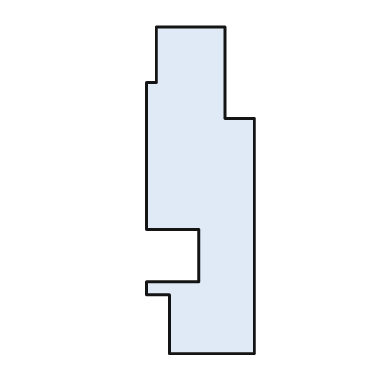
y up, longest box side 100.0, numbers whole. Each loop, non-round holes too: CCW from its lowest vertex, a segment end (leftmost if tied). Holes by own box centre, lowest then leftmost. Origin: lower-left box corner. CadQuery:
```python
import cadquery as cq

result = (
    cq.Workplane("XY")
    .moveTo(7.0, 0.0)
    .lineTo(33.0, 0.0)
    .lineTo(33.0, 72.0)
    .lineTo(24.0, 72.0)
    .lineTo(24.0, 100.0)
    .lineTo(3.0, 100.0)
    .lineTo(3.0, 83.0)
    .lineTo(0.0, 83.0)
    .lineTo(0.0, 38.0)
    .lineTo(16.0, 38.0)
    .lineTo(16.0, 22.0)
    .lineTo(0.0, 22.0)
    .lineTo(0.0, 18.0)
    .lineTo(7.0, 18.0)
    .close()
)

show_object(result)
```